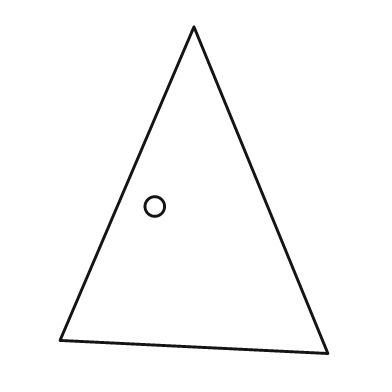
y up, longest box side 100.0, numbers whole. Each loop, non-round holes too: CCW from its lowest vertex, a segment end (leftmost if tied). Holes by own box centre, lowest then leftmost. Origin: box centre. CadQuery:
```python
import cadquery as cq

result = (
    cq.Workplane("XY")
    .moveTo(41.0, -50.0)
    .lineTo(0.0, 50.0)
    .lineTo(-41.0, -46.0)
    .close()
    .moveTo(-12.0, -5.0)
    .circle(3.0)
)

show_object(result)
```